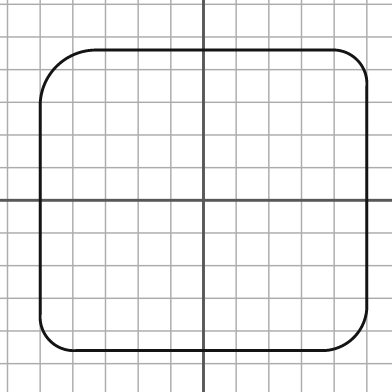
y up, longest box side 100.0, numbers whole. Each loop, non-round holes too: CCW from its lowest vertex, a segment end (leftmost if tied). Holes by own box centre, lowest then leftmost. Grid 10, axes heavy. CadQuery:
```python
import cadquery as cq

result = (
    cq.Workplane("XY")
    .moveTo(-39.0, -46.0)
    .lineTo(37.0, -46.0)
    .threePointArc((46.0, -42.0), (50.0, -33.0))
    .lineTo(50.0, 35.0)
    .threePointArc((47.0, 43.0), (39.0, 46.0))
    .lineTo(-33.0, 46.0)
    .threePointArc((-45.0, 41.0), (-50.0, 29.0))
    .lineTo(-50.0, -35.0)
    .threePointArc((-47.0, -43.0), (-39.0, -46.0))
    .close()
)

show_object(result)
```